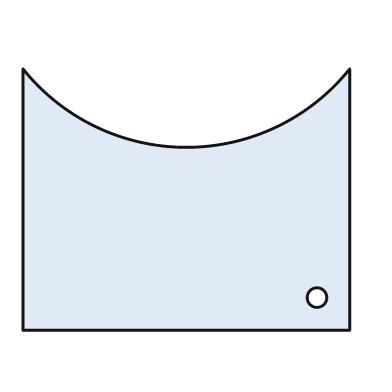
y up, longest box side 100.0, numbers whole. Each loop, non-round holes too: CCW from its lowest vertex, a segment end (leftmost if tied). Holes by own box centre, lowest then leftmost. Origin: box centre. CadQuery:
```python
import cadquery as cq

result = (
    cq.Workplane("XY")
    .moveTo(-50.0, -40.0)
    .lineTo(50.0, -40.0)
    .lineTo(50.0, 40.0)
    .threePointArc((0.0, 16.0), (-50.0, 40.0))
    .close()
    .moveTo(40.0, -30.0)
    .circle(3.0)
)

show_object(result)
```